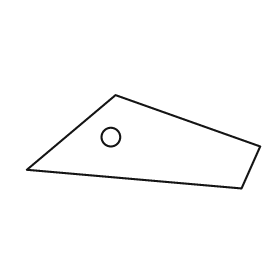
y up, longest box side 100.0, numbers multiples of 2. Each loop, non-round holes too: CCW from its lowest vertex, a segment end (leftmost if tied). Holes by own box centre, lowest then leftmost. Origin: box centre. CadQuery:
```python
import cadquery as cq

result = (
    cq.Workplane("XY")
    .moveTo(42.0, -20.0)
    .lineTo(50.0, -2.0)
    .lineTo(-12.0, 20.0)
    .lineTo(-50.0, -12.0)
    .close()
    .moveTo(-14.0, 2.0)
    .circle(4.0)
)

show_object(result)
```